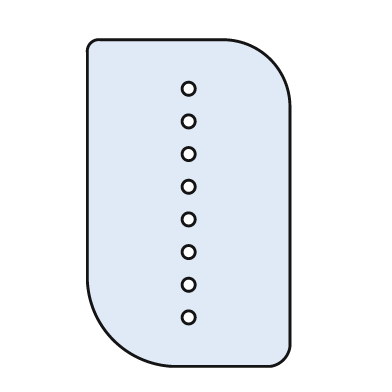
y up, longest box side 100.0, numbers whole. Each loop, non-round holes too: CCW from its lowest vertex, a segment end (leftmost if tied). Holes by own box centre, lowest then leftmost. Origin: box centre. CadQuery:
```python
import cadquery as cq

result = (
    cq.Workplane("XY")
    .moveTo(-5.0, -50.0)
    .lineTo(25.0, -50.0)
    .threePointArc((29.0, -48.0), (31.0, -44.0))
    .lineTo(31.0, 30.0)
    .threePointArc((25.0, 44.0), (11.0, 50.0))
    .lineTo(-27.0, 50.0)
    .threePointArc((-30.0, 49.0), (-31.0, 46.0))
    .lineTo(-31.0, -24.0)
    .threePointArc((-23.0, -42.0), (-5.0, -50.0))
    .close()
    .moveTo(0.0, -35.0)
    .circle(2.0)
    .moveTo(0.0, -25.0)
    .circle(2.0)
    .moveTo(0.0, -15.0)
    .circle(2.0)
    .moveTo(0.0, -5.0)
    .circle(2.0)
    .moveTo(0.0, 5.0)
    .circle(2.0)
    .moveTo(0.0, 15.0)
    .circle(2.0)
    .moveTo(0.0, 25.0)
    .circle(2.0)
    .moveTo(0.0, 35.0)
    .circle(2.0)
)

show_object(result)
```